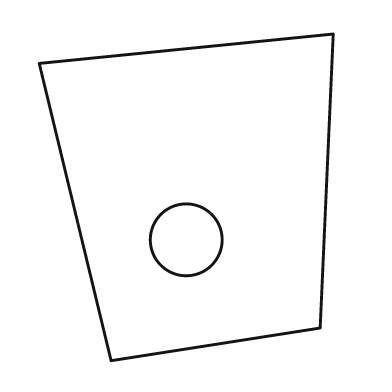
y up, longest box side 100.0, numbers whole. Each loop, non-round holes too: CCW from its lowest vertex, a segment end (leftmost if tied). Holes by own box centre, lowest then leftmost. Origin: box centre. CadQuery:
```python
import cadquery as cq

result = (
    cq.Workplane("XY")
    .moveTo(-23.0, -50.0)
    .lineTo(41.0, -40.0)
    .lineTo(45.0, 50.0)
    .lineTo(-45.0, 41.0)
    .close()
    .moveTo(0.0, -13.0)
    .circle(11.0)
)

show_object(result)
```